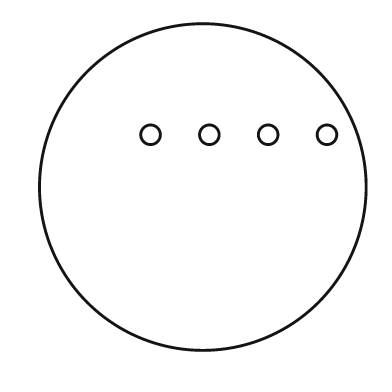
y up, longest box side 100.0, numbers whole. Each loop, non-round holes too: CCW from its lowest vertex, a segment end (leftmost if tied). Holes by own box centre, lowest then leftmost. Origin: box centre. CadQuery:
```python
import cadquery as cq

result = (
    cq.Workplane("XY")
    .moveTo(0.0, 0.0)
    .circle(50.0)
    .moveTo(-16.0, 16.0)
    .circle(3.0)
    .moveTo(2.0, 16.0)
    .circle(3.0)
    .moveTo(20.0, 16.0)
    .circle(3.0)
    .moveTo(38.0, 16.0)
    .circle(3.0)
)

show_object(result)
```